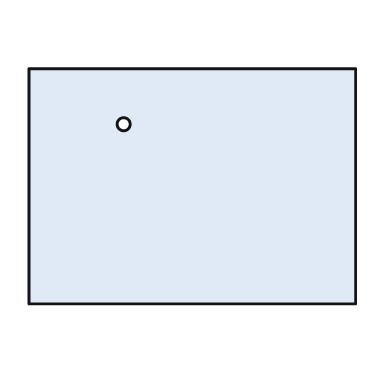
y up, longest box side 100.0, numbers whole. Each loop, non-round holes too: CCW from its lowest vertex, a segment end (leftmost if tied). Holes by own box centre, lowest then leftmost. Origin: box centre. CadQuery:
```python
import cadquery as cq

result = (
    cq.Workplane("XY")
    .moveTo(-50.0, -36.0)
    .lineTo(50.0, -36.0)
    .lineTo(50.0, 36.0)
    .lineTo(-50.0, 36.0)
    .close()
    .moveTo(-21.0, 19.0)
    .circle(2.0)
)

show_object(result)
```